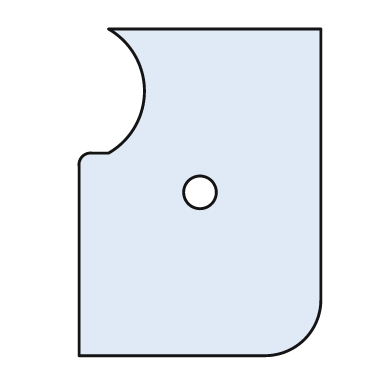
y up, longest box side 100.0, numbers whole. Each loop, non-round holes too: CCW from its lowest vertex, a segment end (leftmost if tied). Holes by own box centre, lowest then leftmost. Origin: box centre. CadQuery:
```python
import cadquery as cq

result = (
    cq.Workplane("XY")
    .moveTo(-37.0, -50.0)
    .lineTo(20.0, -50.0)
    .threePointArc((32.0, -45.0), (37.0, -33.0))
    .lineTo(37.0, 50.0)
    .lineTo(-28.0, 50.0)
    .threePointArc((-17.0, 31.0), (-28.0, 12.0))
    .lineTo(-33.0, 12.0)
    .threePointArc((-36.0, 11.0), (-37.0, 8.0))
    .close()
    .moveTo(0.0, 0.0)
    .circle(5.0)
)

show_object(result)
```